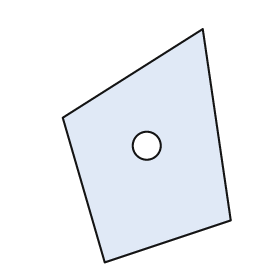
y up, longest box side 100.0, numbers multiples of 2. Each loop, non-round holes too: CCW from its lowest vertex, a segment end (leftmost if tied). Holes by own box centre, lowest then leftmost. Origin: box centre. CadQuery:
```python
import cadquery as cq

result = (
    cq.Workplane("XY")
    .moveTo(-18.0, -50.0)
    .lineTo(36.0, -32.0)
    .lineTo(24.0, 50.0)
    .lineTo(-36.0, 12.0)
    .close()
    .moveTo(0.0, 0.0)
    .circle(6.0)
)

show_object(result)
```